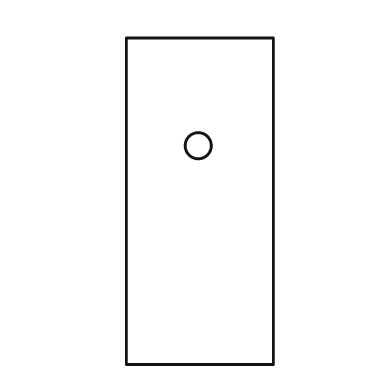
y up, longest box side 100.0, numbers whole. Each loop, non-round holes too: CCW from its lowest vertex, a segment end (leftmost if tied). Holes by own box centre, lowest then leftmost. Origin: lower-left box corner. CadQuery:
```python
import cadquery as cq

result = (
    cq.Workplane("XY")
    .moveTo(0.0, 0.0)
    .lineTo(45.0, 0.0)
    .lineTo(45.0, 100.0)
    .lineTo(0.0, 100.0)
    .close()
    .moveTo(22.0, 67.0)
    .circle(4.0)
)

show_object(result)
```